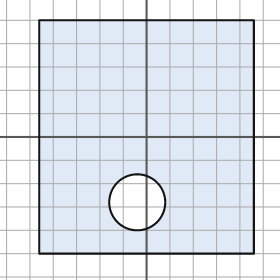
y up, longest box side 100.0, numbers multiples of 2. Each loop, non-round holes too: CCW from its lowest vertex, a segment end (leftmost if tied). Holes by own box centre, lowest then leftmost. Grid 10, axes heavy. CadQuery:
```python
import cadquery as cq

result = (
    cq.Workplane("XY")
    .moveTo(-46.0, -50.0)
    .lineTo(46.0, -50.0)
    .lineTo(46.0, 50.0)
    .lineTo(-46.0, 50.0)
    .close()
    .moveTo(-4.0, -28.0)
    .circle(12.0)
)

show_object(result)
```